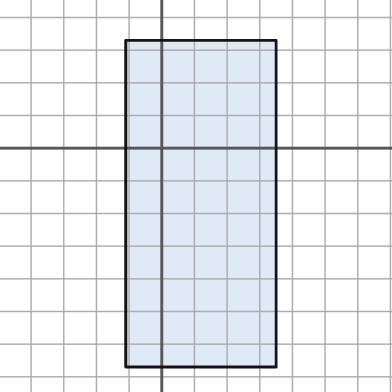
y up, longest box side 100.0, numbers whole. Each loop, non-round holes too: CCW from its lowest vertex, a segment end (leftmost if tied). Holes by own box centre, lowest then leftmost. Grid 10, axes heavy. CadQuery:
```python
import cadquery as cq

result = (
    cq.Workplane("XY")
    .moveTo(-11.0, -67.0)
    .lineTo(35.0, -67.0)
    .lineTo(35.0, 33.0)
    .lineTo(-11.0, 33.0)
    .close()
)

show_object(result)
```